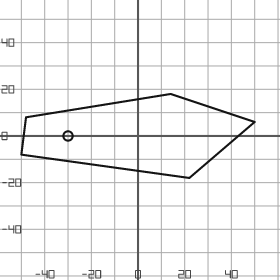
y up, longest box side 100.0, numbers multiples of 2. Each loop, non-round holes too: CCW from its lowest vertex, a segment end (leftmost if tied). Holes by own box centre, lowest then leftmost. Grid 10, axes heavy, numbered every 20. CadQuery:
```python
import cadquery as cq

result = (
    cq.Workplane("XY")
    .moveTo(22.0, -18.0)
    .lineTo(50.0, 6.0)
    .lineTo(14.0, 18.0)
    .lineTo(-48.0, 8.0)
    .lineTo(-50.0, -8.0)
    .close()
    .moveTo(-30.0, 0.0)
    .circle(2.0)
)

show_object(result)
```